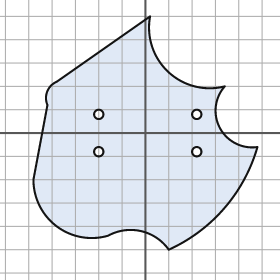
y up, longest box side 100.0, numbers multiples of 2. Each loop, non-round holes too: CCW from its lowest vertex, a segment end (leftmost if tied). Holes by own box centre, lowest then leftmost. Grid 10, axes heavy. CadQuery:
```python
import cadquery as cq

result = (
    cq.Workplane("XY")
    .moveTo(10.0, -50.0)
    .threePointArc((34.0, -32.0), (48.0, -6.0))
    .threePointArc((32.0, 2.0), (34.0, 20.0))
    .threePointArc((10.0, 26.0), (2.0, 50.0))
    .lineTo(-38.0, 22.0)
    .threePointArc((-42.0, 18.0), (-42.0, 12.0))
    .lineTo(-48.0, -20.0)
    .threePointArc((-38.0, -40.0), (-16.0, -44.0))
    .threePointArc((-2.0, -42.0), (10.0, -50.0))
    .close()
    .moveTo(-20.0, -8.0)
    .circle(2.0)
    .moveTo(22.0, -8.0)
    .circle(2.0)
    .moveTo(-20.0, 8.0)
    .circle(2.0)
    .moveTo(22.0, 8.0)
    .circle(2.0)
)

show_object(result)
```